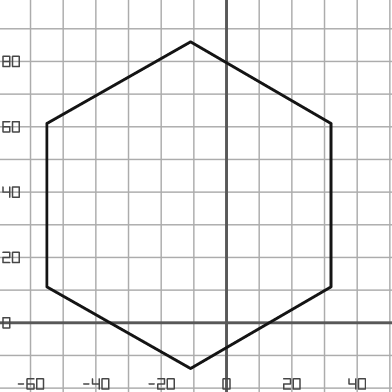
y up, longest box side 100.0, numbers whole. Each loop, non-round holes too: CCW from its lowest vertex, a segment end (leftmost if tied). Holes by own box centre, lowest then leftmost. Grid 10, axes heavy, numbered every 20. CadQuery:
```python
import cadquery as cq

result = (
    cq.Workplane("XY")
    .moveTo(-11.0, -14.0)
    .lineTo(32.0, 11.0)
    .lineTo(32.0, 61.0)
    .lineTo(-11.0, 86.0)
    .lineTo(-55.0, 61.0)
    .lineTo(-55.0, 11.0)
    .close()
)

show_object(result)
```